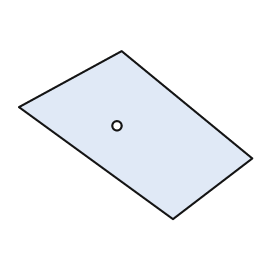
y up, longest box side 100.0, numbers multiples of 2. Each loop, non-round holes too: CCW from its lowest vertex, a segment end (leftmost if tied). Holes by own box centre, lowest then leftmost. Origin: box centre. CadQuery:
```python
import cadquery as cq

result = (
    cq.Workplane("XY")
    .moveTo(16.0, -36.0)
    .lineTo(50.0, -10.0)
    .lineTo(-6.0, 36.0)
    .lineTo(-50.0, 12.0)
    .close()
    .moveTo(-8.0, 4.0)
    .circle(2.0)
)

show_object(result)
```